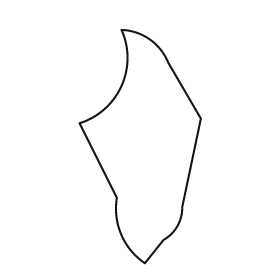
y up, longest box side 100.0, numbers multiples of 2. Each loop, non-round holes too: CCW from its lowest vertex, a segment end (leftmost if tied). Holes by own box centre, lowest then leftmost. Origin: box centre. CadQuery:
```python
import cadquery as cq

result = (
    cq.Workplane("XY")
    .moveTo(2.0, -50.0)
    .lineTo(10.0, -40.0)
    .threePointArc((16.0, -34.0), (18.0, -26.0))
    .lineTo(26.0, 12.0)
    .lineTo(12.0, 36.0)
    .threePointArc((4.0, 46.0), (-8.0, 50.0))
    .threePointArc((-8.0, 26.0), (-26.0, 10.0))
    .lineTo(-10.0, -22.0)
    .threePointArc((-8.0, -38.0), (2.0, -50.0))
    .close()
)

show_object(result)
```